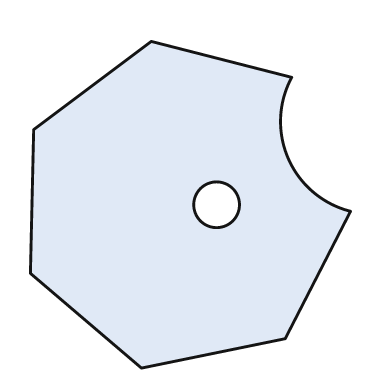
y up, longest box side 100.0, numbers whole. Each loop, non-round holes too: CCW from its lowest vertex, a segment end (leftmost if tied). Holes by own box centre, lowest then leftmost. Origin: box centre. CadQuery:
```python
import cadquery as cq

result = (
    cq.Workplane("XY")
    .moveTo(-15.0, -50.0)
    .lineTo(29.0, -41.0)
    .lineTo(49.0, -2.0)
    .threePointArc((30.0, 14.0), (31.0, 39.0))
    .lineTo(-12.0, 50.0)
    .lineTo(-48.0, 23.0)
    .lineTo(-49.0, -21.0)
    .close()
    .moveTo(8.0, 0.0)
    .circle(7.0)
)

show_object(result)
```